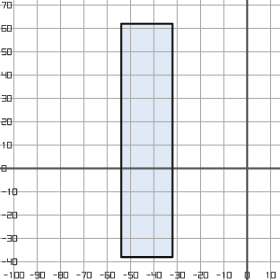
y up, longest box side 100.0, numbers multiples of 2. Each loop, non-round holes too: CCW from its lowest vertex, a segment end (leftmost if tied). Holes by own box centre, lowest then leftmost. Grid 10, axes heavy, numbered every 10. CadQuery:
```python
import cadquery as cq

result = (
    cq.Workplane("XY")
    .moveTo(-54.0, -38.0)
    .lineTo(-32.0, -38.0)
    .lineTo(-32.0, 62.0)
    .lineTo(-54.0, 62.0)
    .close()
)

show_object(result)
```